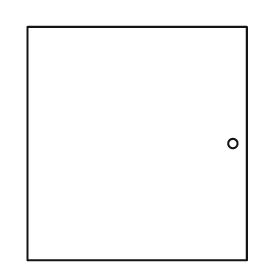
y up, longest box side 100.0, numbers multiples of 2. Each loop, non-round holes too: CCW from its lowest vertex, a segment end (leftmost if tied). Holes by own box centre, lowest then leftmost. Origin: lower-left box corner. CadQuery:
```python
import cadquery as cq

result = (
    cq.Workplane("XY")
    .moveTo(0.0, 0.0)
    .lineTo(94.0, 0.0)
    .lineTo(94.0, 100.0)
    .lineTo(0.0, 100.0)
    .close()
    .moveTo(88.0, 50.0)
    .circle(2.0)
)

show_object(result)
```